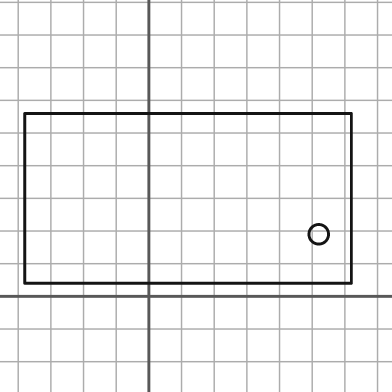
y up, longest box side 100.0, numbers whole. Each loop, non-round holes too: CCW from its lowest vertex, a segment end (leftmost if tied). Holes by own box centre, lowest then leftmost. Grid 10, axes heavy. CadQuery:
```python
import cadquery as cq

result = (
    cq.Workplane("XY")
    .moveTo(-38.0, 4.0)
    .lineTo(62.0, 4.0)
    .lineTo(62.0, 56.0)
    .lineTo(-38.0, 56.0)
    .close()
    .moveTo(52.0, 19.0)
    .circle(3.0)
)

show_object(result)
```